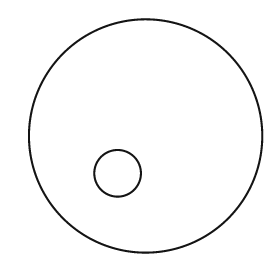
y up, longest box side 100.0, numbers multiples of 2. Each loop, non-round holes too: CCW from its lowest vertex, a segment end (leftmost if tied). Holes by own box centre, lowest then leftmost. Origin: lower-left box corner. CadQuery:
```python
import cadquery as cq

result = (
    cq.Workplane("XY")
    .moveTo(50.0, 50.0)
    .circle(50.0)
    .moveTo(38.0, 34.0)
    .circle(10.0)
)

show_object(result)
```